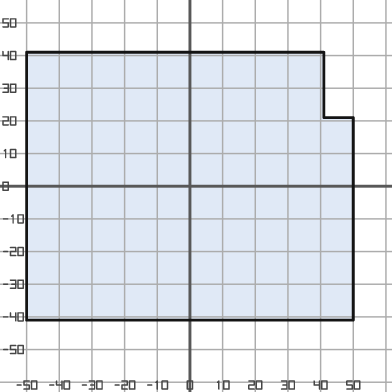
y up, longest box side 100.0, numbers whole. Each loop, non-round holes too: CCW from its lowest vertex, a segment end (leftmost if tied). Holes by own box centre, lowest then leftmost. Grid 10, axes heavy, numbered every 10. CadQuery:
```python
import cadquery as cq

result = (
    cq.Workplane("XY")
    .moveTo(-50.0, -41.0)
    .lineTo(50.0, -41.0)
    .lineTo(50.0, 21.0)
    .lineTo(41.0, 21.0)
    .lineTo(41.0, 41.0)
    .lineTo(-50.0, 41.0)
    .close()
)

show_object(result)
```